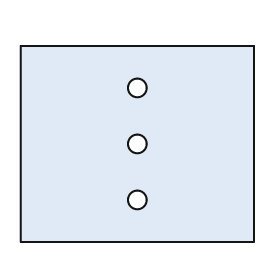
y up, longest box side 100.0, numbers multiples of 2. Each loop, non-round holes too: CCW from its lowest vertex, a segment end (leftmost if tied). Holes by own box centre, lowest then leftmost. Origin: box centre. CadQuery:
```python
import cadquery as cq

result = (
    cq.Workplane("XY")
    .moveTo(-50.0, -42.0)
    .lineTo(50.0, -42.0)
    .lineTo(50.0, 42.0)
    .lineTo(-50.0, 42.0)
    .close()
    .moveTo(0.0, -24.0)
    .circle(4.0)
    .moveTo(0.0, 0.0)
    .circle(4.0)
    .moveTo(0.0, 24.0)
    .circle(4.0)
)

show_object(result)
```